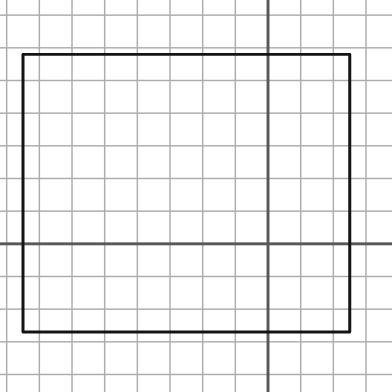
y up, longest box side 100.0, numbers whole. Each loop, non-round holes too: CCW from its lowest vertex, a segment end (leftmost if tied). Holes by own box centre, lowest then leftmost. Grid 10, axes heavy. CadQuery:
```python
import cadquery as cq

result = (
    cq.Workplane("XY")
    .moveTo(-75.0, -27.0)
    .lineTo(25.0, -27.0)
    .lineTo(25.0, 58.0)
    .lineTo(-75.0, 58.0)
    .close()
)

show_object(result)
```